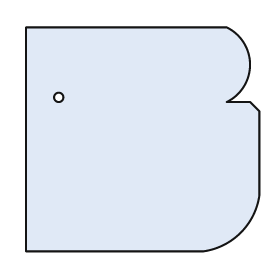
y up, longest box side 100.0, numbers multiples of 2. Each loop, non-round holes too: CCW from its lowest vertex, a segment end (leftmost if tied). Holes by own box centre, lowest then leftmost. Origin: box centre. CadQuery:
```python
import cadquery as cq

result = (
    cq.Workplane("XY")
    .moveTo(-50.0, -48.0)
    .lineTo(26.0, -48.0)
    .threePointArc((42.0, -40.0), (50.0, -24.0))
    .lineTo(50.0, 12.0)
    .lineTo(46.0, 16.0)
    .lineTo(36.0, 16.0)
    .threePointArc((46.0, 32.0), (36.0, 48.0))
    .lineTo(-50.0, 48.0)
    .close()
    .moveTo(-36.0, 18.0)
    .circle(2.0)
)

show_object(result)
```